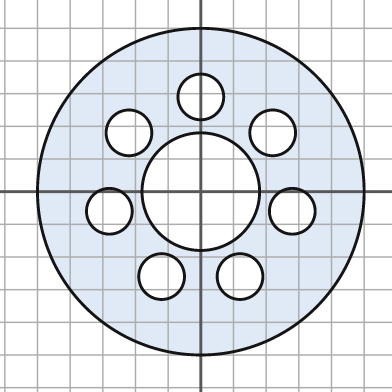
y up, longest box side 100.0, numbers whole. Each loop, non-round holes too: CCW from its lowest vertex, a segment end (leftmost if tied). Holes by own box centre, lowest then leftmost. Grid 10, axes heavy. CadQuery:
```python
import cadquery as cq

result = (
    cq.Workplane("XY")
    .moveTo(0.0, 0.0)
    .circle(50.0)
    .moveTo(-12.0, -26.0)
    .circle(7.0)
    .moveTo(12.0, -26.0)
    .circle(7.0)
    .moveTo(-28.0, -6.0)
    .circle(7.0)
    .moveTo(28.0, -6.0)
    .circle(7.0)
    .moveTo(0.0, 0.0)
    .circle(18.0)
    .moveTo(-22.0, 18.0)
    .circle(7.0)
    .moveTo(22.0, 18.0)
    .circle(7.0)
    .moveTo(0.0, 29.0)
    .circle(7.0)
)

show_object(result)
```